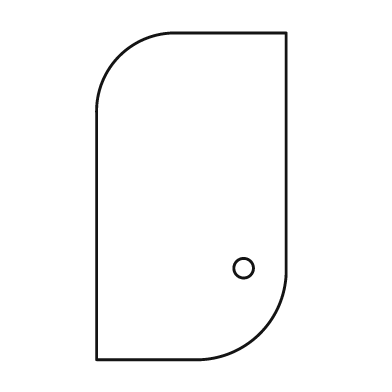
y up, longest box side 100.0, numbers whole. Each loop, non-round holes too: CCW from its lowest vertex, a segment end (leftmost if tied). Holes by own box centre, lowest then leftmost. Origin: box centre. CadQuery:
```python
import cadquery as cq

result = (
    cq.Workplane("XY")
    .moveTo(-29.0, -50.0)
    .lineTo(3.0, -50.0)
    .threePointArc((21.0, -42.0), (29.0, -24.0))
    .lineTo(29.0, 50.0)
    .lineTo(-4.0, 50.0)
    .threePointArc((-22.0, 43.0), (-29.0, 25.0))
    .close()
    .moveTo(16.0, -22.0)
    .circle(3.0)
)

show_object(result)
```